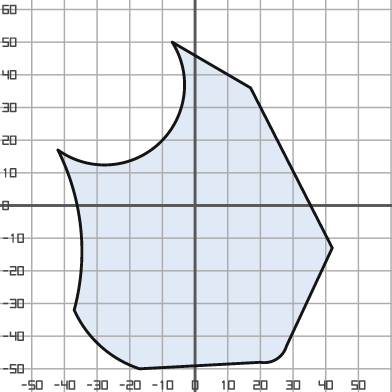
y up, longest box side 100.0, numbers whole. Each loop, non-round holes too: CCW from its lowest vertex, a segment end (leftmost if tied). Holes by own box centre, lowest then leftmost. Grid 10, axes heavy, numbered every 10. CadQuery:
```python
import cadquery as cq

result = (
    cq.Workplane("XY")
    .moveTo(-17.0, -50.0)
    .lineTo(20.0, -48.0)
    .threePointArc((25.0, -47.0), (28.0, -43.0))
    .lineTo(42.0, -13.0)
    .lineTo(17.0, 36.0)
    .lineTo(-7.0, 50.0)
    .threePointArc((-11.0, 19.0), (-42.0, 17.0))
    .threePointArc((-35.0, -7.0), (-37.0, -32.0))
    .threePointArc((-29.0, -43.0), (-17.0, -50.0))
    .close()
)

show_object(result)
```